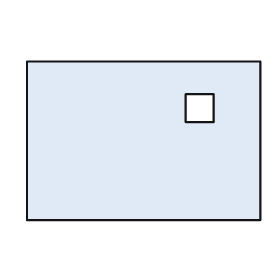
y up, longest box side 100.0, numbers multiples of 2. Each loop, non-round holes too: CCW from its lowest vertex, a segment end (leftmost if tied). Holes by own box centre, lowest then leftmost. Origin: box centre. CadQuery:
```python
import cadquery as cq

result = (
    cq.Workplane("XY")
    .moveTo(-50.0, -34.0)
    .lineTo(50.0, -34.0)
    .lineTo(50.0, 34.0)
    .lineTo(-50.0, 34.0)
    .close()
    .moveTo(18.0, 8.0)
    .lineTo(30.0, 8.0)
    .lineTo(30.0, 20.0)
    .lineTo(18.0, 20.0)
    .close()
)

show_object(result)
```